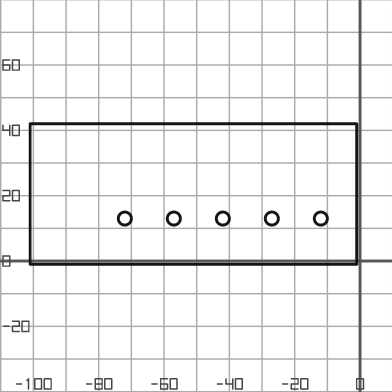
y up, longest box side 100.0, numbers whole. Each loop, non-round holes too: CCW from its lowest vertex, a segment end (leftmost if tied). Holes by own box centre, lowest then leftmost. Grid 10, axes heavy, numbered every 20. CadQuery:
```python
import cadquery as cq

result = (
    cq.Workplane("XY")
    .moveTo(-101.0, -1.0)
    .lineTo(-1.0, -1.0)
    .lineTo(-1.0, 42.0)
    .lineTo(-101.0, 42.0)
    .close()
    .moveTo(-72.0, 13.0)
    .circle(2.0)
    .moveTo(-57.0, 13.0)
    .circle(2.0)
    .moveTo(-42.0, 13.0)
    .circle(2.0)
    .moveTo(-27.0, 13.0)
    .circle(2.0)
    .moveTo(-12.0, 13.0)
    .circle(2.0)
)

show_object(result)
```